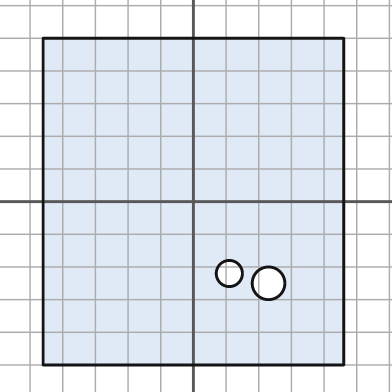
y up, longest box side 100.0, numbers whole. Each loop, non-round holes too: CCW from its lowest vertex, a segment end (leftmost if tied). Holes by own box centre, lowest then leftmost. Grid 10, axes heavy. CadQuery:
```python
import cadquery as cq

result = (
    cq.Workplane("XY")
    .moveTo(-46.0, -50.0)
    .lineTo(46.0, -50.0)
    .lineTo(46.0, 50.0)
    .lineTo(-46.0, 50.0)
    .close()
    .moveTo(23.0, -25.0)
    .circle(5.0)
    .moveTo(11.0, -22.0)
    .circle(4.0)
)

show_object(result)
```